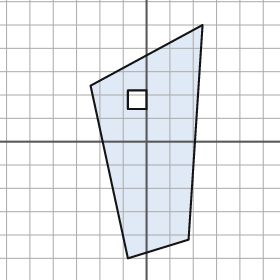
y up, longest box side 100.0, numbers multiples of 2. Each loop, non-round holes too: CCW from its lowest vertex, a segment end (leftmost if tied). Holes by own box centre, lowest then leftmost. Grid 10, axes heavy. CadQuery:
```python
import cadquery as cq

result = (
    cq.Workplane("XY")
    .moveTo(-8.0, -50.0)
    .lineTo(18.0, -42.0)
    .lineTo(24.0, 50.0)
    .lineTo(-24.0, 24.0)
    .close()
    .moveTo(-8.0, 14.0)
    .lineTo(0.0, 14.0)
    .lineTo(0.0, 22.0)
    .lineTo(-8.0, 22.0)
    .close()
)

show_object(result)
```